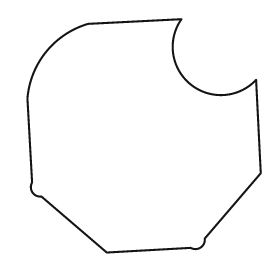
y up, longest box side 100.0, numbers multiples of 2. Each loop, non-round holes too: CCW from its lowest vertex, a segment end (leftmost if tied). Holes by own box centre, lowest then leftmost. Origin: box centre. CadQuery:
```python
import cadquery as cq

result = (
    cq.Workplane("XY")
    .moveTo(-16.0, -50.0)
    .lineTo(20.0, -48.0)
    .threePointArc((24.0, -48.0), (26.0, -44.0))
    .lineTo(50.0, -16.0)
    .lineTo(48.0, 24.0)
    .threePointArc((20.0, 22.0), (16.0, 50.0))
    .lineTo(-24.0, 48.0)
    .threePointArc((-42.0, 36.0), (-50.0, 16.0))
    .lineTo(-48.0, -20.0)
    .threePointArc((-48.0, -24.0), (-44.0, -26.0))
    .close()
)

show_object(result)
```